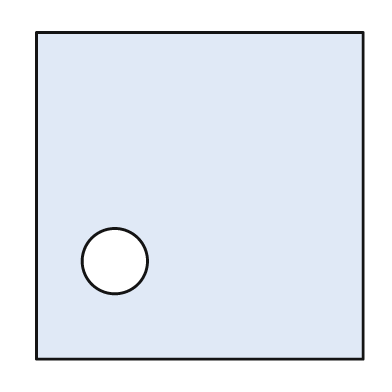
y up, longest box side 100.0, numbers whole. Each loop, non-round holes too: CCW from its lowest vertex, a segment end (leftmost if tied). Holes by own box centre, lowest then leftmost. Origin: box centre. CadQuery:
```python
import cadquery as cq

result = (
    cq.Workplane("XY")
    .moveTo(-50.0, -50.0)
    .lineTo(50.0, -50.0)
    .lineTo(50.0, 50.0)
    .lineTo(-50.0, 50.0)
    .close()
    .moveTo(-26.0, -20.0)
    .circle(10.0)
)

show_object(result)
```